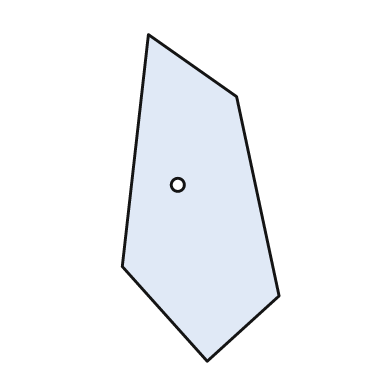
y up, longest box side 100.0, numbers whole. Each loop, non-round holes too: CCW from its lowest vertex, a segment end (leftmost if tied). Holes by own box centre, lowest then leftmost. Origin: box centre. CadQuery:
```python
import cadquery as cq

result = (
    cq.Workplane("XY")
    .moveTo(2.0, -50.0)
    .lineTo(24.0, -30.0)
    .lineTo(11.0, 31.0)
    .lineTo(-16.0, 50.0)
    .lineTo(-24.0, -21.0)
    .close()
    .moveTo(-7.0, 4.0)
    .circle(2.0)
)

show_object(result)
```